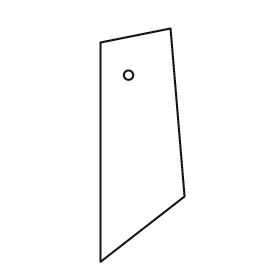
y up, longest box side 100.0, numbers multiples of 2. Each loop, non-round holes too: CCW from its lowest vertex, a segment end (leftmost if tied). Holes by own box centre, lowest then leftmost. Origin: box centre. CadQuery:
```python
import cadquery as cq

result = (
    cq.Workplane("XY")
    .moveTo(-18.0, -50.0)
    .lineTo(18.0, -22.0)
    .lineTo(12.0, 50.0)
    .lineTo(-18.0, 44.0)
    .close()
    .moveTo(-6.0, 30.0)
    .circle(2.0)
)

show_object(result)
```